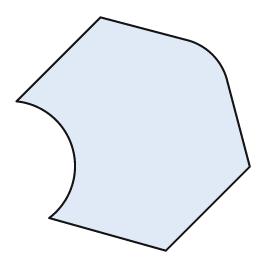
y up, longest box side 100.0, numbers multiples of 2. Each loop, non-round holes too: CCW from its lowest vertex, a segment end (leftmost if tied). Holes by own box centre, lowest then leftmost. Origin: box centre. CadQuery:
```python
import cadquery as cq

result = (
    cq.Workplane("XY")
    .moveTo(14.0, -50.0)
    .lineTo(50.0, -14.0)
    .lineTo(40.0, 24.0)
    .threePointArc((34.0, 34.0), (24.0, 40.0))
    .lineTo(-14.0, 50.0)
    .lineTo(-50.0, 14.0)
    .threePointArc((-26.0, -6.0), (-36.0, -36.0))
    .close()
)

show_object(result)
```